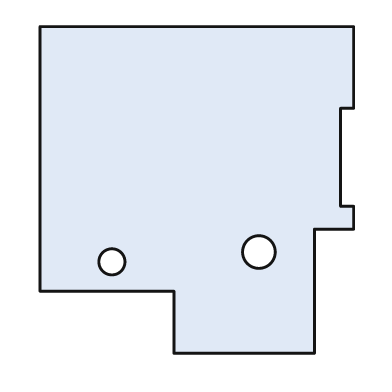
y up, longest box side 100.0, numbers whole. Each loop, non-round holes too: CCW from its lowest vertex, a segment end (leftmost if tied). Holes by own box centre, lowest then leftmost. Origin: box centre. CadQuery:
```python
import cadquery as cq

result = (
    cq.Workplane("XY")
    .moveTo(-7.0, -50.0)
    .lineTo(36.0, -50.0)
    .lineTo(36.0, -12.0)
    .lineTo(48.0, -12.0)
    .lineTo(48.0, -5.0)
    .lineTo(44.0, -5.0)
    .lineTo(44.0, 25.0)
    .lineTo(48.0, 25.0)
    .lineTo(48.0, 50.0)
    .lineTo(-48.0, 50.0)
    .lineTo(-48.0, -31.0)
    .lineTo(-7.0, -31.0)
    .close()
    .moveTo(-26.0, -22.0)
    .circle(4.0)
    .moveTo(19.0, -19.0)
    .circle(5.0)
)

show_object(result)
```